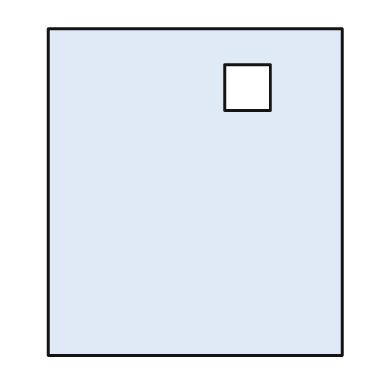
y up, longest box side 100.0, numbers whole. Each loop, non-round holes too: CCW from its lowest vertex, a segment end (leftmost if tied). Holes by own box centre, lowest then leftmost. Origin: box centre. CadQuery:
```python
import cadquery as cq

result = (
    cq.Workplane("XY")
    .moveTo(-45.0, -50.0)
    .lineTo(45.0, -50.0)
    .lineTo(45.0, 50.0)
    .lineTo(-45.0, 50.0)
    .close()
    .moveTo(9.0, 25.0)
    .lineTo(23.0, 25.0)
    .lineTo(23.0, 39.0)
    .lineTo(9.0, 39.0)
    .close()
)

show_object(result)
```